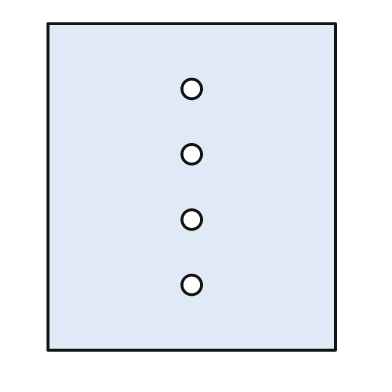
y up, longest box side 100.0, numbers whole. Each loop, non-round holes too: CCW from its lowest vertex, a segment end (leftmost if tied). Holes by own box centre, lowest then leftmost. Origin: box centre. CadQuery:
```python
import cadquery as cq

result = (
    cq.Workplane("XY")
    .moveTo(-44.0, -50.0)
    .lineTo(44.0, -50.0)
    .lineTo(44.0, 50.0)
    .lineTo(-44.0, 50.0)
    .close()
    .moveTo(0.0, -30.0)
    .circle(3.0)
    .moveTo(0.0, -10.0)
    .circle(3.0)
    .moveTo(0.0, 10.0)
    .circle(3.0)
    .moveTo(0.0, 30.0)
    .circle(3.0)
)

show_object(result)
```